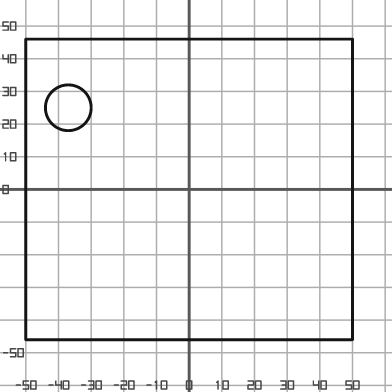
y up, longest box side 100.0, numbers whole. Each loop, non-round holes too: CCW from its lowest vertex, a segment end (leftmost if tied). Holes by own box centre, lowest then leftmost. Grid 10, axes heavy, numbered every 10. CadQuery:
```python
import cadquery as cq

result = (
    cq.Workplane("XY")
    .moveTo(-50.0, -46.0)
    .lineTo(50.0, -46.0)
    .lineTo(50.0, 46.0)
    .lineTo(-50.0, 46.0)
    .close()
    .moveTo(-37.0, 25.0)
    .circle(7.0)
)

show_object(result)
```